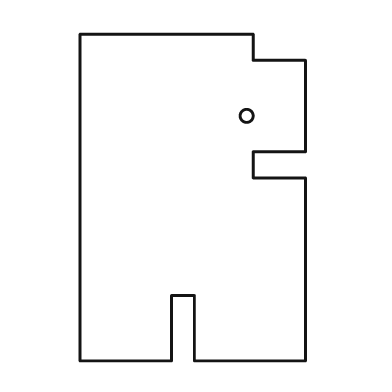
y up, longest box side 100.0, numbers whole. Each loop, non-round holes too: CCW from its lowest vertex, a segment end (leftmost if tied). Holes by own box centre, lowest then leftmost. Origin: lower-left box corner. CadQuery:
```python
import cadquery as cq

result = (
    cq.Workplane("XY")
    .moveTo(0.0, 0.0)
    .lineTo(28.0, 0.0)
    .lineTo(28.0, 20.0)
    .lineTo(35.0, 20.0)
    .lineTo(35.0, 0.0)
    .lineTo(69.0, 0.0)
    .lineTo(69.0, 56.0)
    .lineTo(53.0, 56.0)
    .lineTo(53.0, 64.0)
    .lineTo(69.0, 64.0)
    .lineTo(69.0, 92.0)
    .lineTo(53.0, 92.0)
    .lineTo(53.0, 100.0)
    .lineTo(0.0, 100.0)
    .close()
    .moveTo(51.0, 75.0)
    .circle(2.0)
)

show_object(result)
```